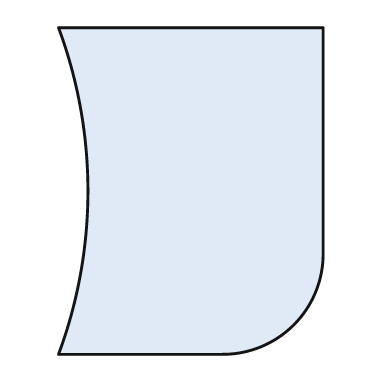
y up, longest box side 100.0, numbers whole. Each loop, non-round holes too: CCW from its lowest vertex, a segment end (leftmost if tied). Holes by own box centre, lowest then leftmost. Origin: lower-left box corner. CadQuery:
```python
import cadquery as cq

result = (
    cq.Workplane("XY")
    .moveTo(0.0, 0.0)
    .lineTo(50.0, 0.0)
    .threePointArc((72.0, 9.0), (81.0, 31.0))
    .lineTo(81.0, 100.0)
    .lineTo(0.0, 100.0)
    .threePointArc((9.0, 50.0), (0.0, 0.0))
    .close()
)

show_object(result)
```